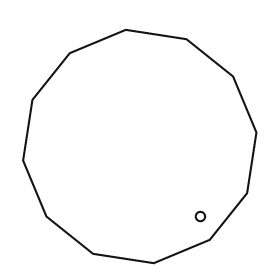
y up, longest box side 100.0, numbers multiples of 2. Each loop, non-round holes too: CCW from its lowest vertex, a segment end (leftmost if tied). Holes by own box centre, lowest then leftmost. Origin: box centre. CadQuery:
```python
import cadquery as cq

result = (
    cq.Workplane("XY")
    .moveTo(6.0, -50.0)
    .lineTo(30.0, -40.0)
    .lineTo(46.0, -20.0)
    .lineTo(50.0, 6.0)
    .lineTo(40.0, 30.0)
    .lineTo(20.0, 46.0)
    .lineTo(-6.0, 50.0)
    .lineTo(-30.0, 40.0)
    .lineTo(-46.0, 20.0)
    .lineTo(-50.0, -6.0)
    .lineTo(-40.0, -30.0)
    .lineTo(-20.0, -46.0)
    .close()
    .moveTo(26.0, -30.0)
    .circle(2.0)
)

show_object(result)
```